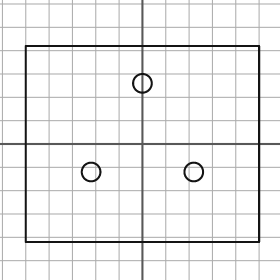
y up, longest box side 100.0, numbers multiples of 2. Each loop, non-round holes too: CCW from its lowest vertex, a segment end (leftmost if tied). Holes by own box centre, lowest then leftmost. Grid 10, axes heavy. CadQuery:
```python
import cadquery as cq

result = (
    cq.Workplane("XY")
    .moveTo(-50.0, -42.0)
    .lineTo(50.0, -42.0)
    .lineTo(50.0, 42.0)
    .lineTo(-50.0, 42.0)
    .close()
    .moveTo(-22.0, -12.0)
    .circle(4.0)
    .moveTo(22.0, -12.0)
    .circle(4.0)
    .moveTo(0.0, 26.0)
    .circle(4.0)
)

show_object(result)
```